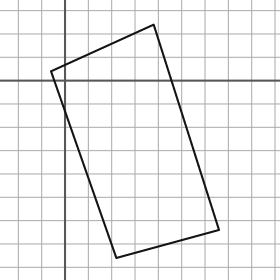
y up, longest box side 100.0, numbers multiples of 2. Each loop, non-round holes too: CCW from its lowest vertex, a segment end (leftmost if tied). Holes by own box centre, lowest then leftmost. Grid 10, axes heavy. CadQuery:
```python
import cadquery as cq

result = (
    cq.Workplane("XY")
    .moveTo(22.0, -76.0)
    .lineTo(66.0, -64.0)
    .lineTo(38.0, 24.0)
    .lineTo(-6.0, 4.0)
    .close()
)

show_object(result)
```